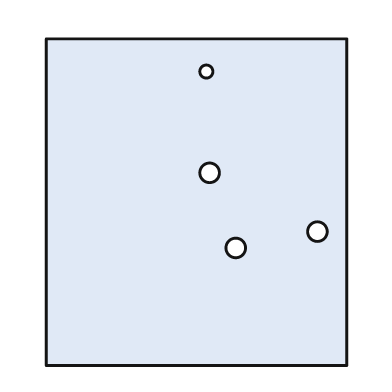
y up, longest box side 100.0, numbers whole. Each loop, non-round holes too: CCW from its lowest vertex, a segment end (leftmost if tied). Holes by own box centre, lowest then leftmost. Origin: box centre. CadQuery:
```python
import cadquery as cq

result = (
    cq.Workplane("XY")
    .moveTo(-46.0, -50.0)
    .lineTo(46.0, -50.0)
    .lineTo(46.0, 50.0)
    .lineTo(-46.0, 50.0)
    .close()
    .moveTo(12.0, -14.0)
    .circle(3.0)
    .moveTo(37.0, -9.0)
    .circle(3.0)
    .moveTo(4.0, 9.0)
    .circle(3.0)
    .moveTo(3.0, 40.0)
    .circle(2.0)
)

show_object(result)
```